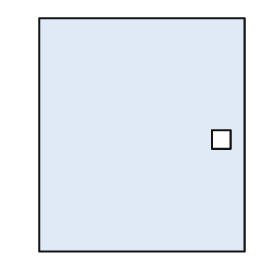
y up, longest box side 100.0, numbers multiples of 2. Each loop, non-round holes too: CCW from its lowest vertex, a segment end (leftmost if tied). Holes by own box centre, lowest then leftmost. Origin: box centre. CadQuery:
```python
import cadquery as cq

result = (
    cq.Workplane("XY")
    .moveTo(-44.0, -50.0)
    .lineTo(44.0, -50.0)
    .lineTo(44.0, 50.0)
    .lineTo(-44.0, 50.0)
    .close()
    .moveTo(30.0, -6.0)
    .lineTo(38.0, -6.0)
    .lineTo(38.0, 2.0)
    .lineTo(30.0, 2.0)
    .close()
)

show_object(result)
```